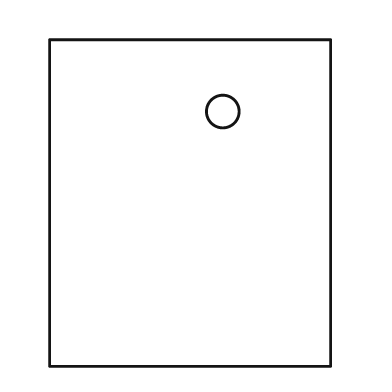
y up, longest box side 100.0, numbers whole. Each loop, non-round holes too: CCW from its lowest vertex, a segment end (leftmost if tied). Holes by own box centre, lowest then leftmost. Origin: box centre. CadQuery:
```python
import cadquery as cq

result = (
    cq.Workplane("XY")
    .moveTo(-43.0, -50.0)
    .lineTo(43.0, -50.0)
    .lineTo(43.0, 50.0)
    .lineTo(-43.0, 50.0)
    .close()
    .moveTo(10.0, 28.0)
    .circle(5.0)
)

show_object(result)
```